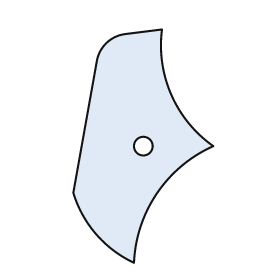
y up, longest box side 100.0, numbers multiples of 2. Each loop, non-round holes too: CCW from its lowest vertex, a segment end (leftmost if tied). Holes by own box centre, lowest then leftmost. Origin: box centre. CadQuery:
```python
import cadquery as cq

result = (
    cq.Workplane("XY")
    .moveTo(-4.0, -50.0)
    .threePointArc((6.0, -20.0), (30.0, 0.0))
    .threePointArc((12.0, 22.0), (8.0, 50.0))
    .lineTo(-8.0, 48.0)
    .threePointArc((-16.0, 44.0), (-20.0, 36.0))
    .lineTo(-30.0, -20.0)
    .threePointArc((-20.0, -38.0), (-4.0, -50.0))
    .close()
    .moveTo(0.0, 0.0)
    .circle(4.0)
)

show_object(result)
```